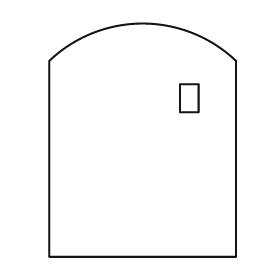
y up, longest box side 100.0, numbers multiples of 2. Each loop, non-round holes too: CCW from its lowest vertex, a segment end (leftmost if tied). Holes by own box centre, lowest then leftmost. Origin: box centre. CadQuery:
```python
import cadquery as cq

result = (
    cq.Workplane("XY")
    .moveTo(-40.0, -50.0)
    .lineTo(40.0, -50.0)
    .lineTo(40.0, 34.0)
    .threePointArc((0.0, 50.0), (-40.0, 34.0))
    .close()
    .moveTo(16.0, 12.0)
    .lineTo(24.0, 12.0)
    .lineTo(24.0, 24.0)
    .lineTo(16.0, 24.0)
    .close()
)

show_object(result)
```